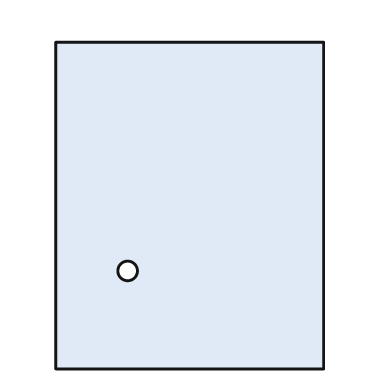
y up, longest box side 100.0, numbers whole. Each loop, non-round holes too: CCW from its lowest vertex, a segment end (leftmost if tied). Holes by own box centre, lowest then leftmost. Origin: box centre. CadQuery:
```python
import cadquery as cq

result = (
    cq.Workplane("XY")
    .moveTo(-41.0, -50.0)
    .lineTo(41.0, -50.0)
    .lineTo(41.0, 50.0)
    .lineTo(-41.0, 50.0)
    .close()
    .moveTo(-19.0, -20.0)
    .circle(3.0)
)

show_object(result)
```